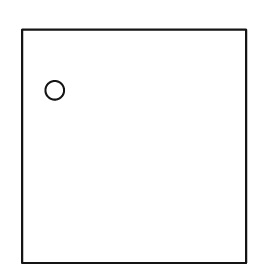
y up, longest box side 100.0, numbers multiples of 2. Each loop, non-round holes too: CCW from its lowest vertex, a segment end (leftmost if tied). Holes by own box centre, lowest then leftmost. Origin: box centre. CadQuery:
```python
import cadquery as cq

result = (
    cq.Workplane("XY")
    .moveTo(-48.0, -50.0)
    .lineTo(48.0, -50.0)
    .lineTo(48.0, 50.0)
    .lineTo(-48.0, 50.0)
    .close()
    .moveTo(-34.0, 24.0)
    .circle(4.0)
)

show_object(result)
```